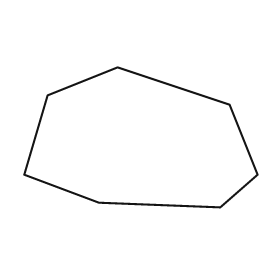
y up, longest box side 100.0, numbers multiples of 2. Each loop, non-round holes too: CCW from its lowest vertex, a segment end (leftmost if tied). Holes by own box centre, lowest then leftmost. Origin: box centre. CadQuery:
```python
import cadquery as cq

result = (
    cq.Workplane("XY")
    .moveTo(34.0, -30.0)
    .lineTo(50.0, -16.0)
    .lineTo(38.0, 14.0)
    .lineTo(-10.0, 30.0)
    .lineTo(-40.0, 18.0)
    .lineTo(-50.0, -16.0)
    .lineTo(-18.0, -28.0)
    .close()
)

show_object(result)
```